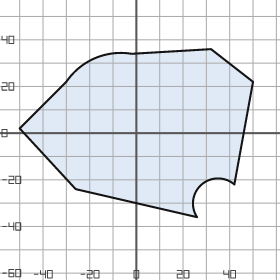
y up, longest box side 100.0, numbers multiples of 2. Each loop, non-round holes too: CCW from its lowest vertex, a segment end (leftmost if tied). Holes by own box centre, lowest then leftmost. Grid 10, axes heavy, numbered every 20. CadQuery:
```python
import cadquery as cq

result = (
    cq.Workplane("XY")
    .moveTo(26.0, -36.0)
    .threePointArc((28.0, -22.0), (42.0, -22.0))
    .lineTo(50.0, 22.0)
    .lineTo(32.0, 36.0)
    .lineTo(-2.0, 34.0)
    .threePointArc((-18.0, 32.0), (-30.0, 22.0))
    .lineTo(-50.0, 2.0)
    .lineTo(-26.0, -24.0)
    .close()
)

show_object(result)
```